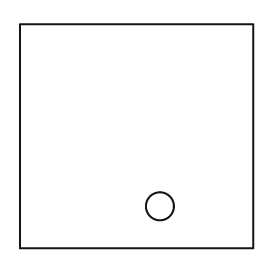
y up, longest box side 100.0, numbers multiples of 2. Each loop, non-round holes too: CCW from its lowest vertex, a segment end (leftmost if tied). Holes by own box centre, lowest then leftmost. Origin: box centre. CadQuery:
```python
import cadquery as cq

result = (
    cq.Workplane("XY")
    .moveTo(-50.0, -48.0)
    .lineTo(50.0, -48.0)
    .lineTo(50.0, 48.0)
    .lineTo(-50.0, 48.0)
    .close()
    .moveTo(10.0, -30.0)
    .circle(6.0)
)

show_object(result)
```